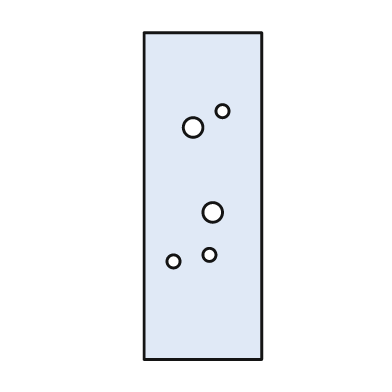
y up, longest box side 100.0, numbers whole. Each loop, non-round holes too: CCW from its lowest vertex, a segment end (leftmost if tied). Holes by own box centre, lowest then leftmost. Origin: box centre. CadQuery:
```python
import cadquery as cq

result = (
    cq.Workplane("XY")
    .moveTo(-18.0, -50.0)
    .lineTo(18.0, -50.0)
    .lineTo(18.0, 50.0)
    .lineTo(-18.0, 50.0)
    .close()
    .moveTo(-9.0, -20.0)
    .circle(2.0)
    .moveTo(2.0, -18.0)
    .circle(2.0)
    .moveTo(3.0, -5.0)
    .circle(3.0)
    .moveTo(-3.0, 21.0)
    .circle(3.0)
    .moveTo(6.0, 26.0)
    .circle(2.0)
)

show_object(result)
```